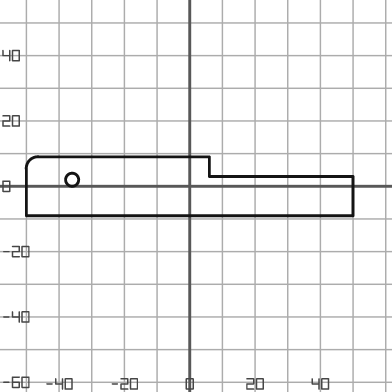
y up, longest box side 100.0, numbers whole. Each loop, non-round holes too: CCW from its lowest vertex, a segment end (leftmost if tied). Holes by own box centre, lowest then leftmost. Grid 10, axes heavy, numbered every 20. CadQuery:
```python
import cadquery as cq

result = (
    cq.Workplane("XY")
    .moveTo(-50.0, -9.0)
    .lineTo(50.0, -9.0)
    .lineTo(50.0, 3.0)
    .lineTo(6.0, 3.0)
    .lineTo(6.0, 9.0)
    .lineTo(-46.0, 9.0)
    .threePointArc((-49.0, 8.0), (-50.0, 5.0))
    .close()
    .moveTo(-36.0, 2.0)
    .circle(2.0)
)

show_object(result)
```